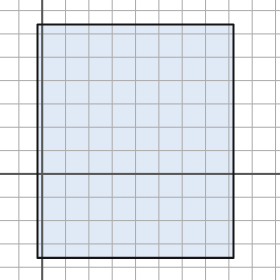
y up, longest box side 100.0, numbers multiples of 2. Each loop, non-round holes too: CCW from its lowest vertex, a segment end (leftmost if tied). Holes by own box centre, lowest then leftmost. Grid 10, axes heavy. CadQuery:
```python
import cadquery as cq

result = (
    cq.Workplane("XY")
    .moveTo(-2.0, -36.0)
    .lineTo(82.0, -36.0)
    .lineTo(82.0, 64.0)
    .lineTo(-2.0, 64.0)
    .close()
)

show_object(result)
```